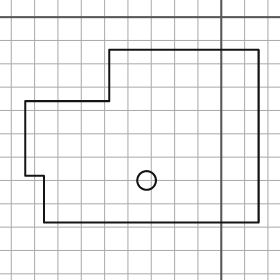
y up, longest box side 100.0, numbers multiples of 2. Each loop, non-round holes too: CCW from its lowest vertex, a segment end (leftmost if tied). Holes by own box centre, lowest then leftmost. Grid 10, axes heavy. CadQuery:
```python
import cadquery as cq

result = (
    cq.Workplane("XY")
    .moveTo(-76.0, -88.0)
    .lineTo(16.0, -88.0)
    .lineTo(16.0, -14.0)
    .lineTo(-48.0, -14.0)
    .lineTo(-48.0, -36.0)
    .lineTo(-84.0, -36.0)
    .lineTo(-84.0, -68.0)
    .lineTo(-76.0, -68.0)
    .close()
    .moveTo(-32.0, -70.0)
    .circle(4.0)
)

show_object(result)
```